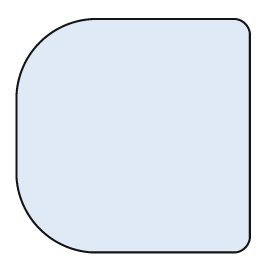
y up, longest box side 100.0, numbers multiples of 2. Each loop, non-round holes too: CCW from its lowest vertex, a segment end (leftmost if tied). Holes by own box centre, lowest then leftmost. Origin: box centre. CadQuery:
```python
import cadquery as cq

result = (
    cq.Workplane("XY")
    .moveTo(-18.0, -50.0)
    .lineTo(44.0, -50.0)
    .threePointArc((48.0, -48.0), (50.0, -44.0))
    .lineTo(50.0, 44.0)
    .threePointArc((48.0, 48.0), (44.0, 50.0))
    .lineTo(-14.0, 50.0)
    .threePointArc((-40.0, 40.0), (-50.0, 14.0))
    .lineTo(-50.0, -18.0)
    .threePointArc((-40.0, -40.0), (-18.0, -50.0))
    .close()
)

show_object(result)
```